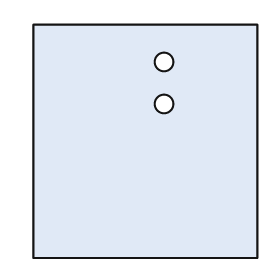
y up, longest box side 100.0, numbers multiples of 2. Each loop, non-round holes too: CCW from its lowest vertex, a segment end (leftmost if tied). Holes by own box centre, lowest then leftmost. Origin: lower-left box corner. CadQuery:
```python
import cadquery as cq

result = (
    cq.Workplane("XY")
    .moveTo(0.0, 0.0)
    .lineTo(96.0, 0.0)
    .lineTo(96.0, 100.0)
    .lineTo(0.0, 100.0)
    .close()
    .moveTo(56.0, 66.0)
    .circle(4.0)
    .moveTo(56.0, 84.0)
    .circle(4.0)
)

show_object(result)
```